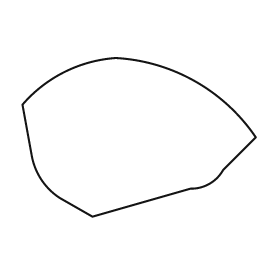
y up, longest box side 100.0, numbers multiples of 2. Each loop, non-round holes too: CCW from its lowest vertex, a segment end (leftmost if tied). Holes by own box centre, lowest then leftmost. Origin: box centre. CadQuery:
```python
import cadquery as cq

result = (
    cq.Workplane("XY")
    .moveTo(-20.0, -34.0)
    .lineTo(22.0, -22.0)
    .threePointArc((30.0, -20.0), (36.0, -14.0))
    .lineTo(50.0, 0.0)
    .threePointArc((24.0, 24.0), (-10.0, 34.0))
    .threePointArc((-32.0, 28.0), (-50.0, 14.0))
    .lineTo(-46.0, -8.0)
    .threePointArc((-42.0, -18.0), (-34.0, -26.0))
    .close()
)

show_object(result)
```